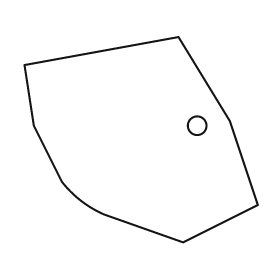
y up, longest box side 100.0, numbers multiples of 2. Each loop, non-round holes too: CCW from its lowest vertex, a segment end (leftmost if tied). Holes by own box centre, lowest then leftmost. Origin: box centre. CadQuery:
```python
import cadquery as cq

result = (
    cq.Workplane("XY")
    .moveTo(18.0, -44.0)
    .lineTo(50.0, -28.0)
    .lineTo(38.0, 8.0)
    .lineTo(16.0, 44.0)
    .lineTo(-50.0, 32.0)
    .lineTo(-46.0, 6.0)
    .lineTo(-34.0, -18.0)
    .threePointArc((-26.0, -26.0), (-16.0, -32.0))
    .close()
    .moveTo(24.0, 6.0)
    .circle(4.0)
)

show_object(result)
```